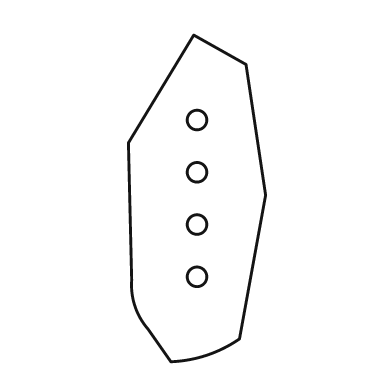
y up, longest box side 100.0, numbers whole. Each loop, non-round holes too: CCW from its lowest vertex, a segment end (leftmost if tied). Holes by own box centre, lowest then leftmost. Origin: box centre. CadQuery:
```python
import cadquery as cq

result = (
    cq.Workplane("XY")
    .moveTo(-8.0, -50.0)
    .threePointArc((3.0, -48.0), (13.0, -43.0))
    .lineTo(21.0, 1.0)
    .lineTo(15.0, 41.0)
    .lineTo(-1.0, 50.0)
    .lineTo(-21.0, 17.0)
    .lineTo(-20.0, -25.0)
    .threePointArc((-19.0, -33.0), (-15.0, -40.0))
    .close()
    .moveTo(0.0, -24.0)
    .circle(3.0)
    .moveTo(0.0, -8.0)
    .circle(3.0)
    .moveTo(0.0, 8.0)
    .circle(3.0)
    .moveTo(0.0, 24.0)
    .circle(3.0)
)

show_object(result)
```